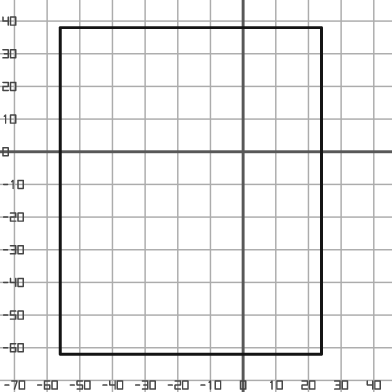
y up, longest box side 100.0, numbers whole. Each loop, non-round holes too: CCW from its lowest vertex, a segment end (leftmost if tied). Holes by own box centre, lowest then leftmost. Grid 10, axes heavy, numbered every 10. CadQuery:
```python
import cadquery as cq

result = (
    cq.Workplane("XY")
    .moveTo(-56.0, -62.0)
    .lineTo(24.0, -62.0)
    .lineTo(24.0, 38.0)
    .lineTo(-56.0, 38.0)
    .close()
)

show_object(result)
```